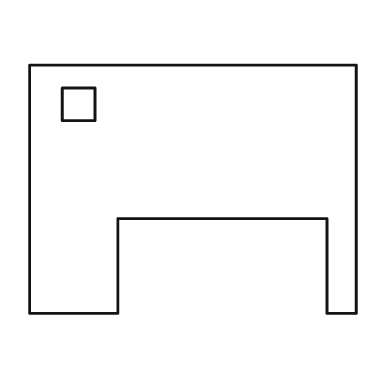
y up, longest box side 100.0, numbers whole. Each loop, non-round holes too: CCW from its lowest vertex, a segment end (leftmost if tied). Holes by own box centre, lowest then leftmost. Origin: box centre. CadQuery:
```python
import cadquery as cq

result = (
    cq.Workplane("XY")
    .moveTo(-50.0, -38.0)
    .lineTo(-23.0, -38.0)
    .lineTo(-23.0, -9.0)
    .lineTo(41.0, -9.0)
    .lineTo(41.0, -38.0)
    .lineTo(50.0, -38.0)
    .lineTo(50.0, 38.0)
    .lineTo(-50.0, 38.0)
    .close()
    .moveTo(-40.0, 21.0)
    .lineTo(-30.0, 21.0)
    .lineTo(-30.0, 31.0)
    .lineTo(-40.0, 31.0)
    .close()
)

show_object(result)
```